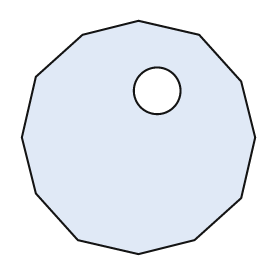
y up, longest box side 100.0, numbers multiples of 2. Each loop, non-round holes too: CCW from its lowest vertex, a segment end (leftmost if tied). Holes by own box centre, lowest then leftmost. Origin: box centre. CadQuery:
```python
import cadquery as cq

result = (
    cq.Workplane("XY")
    .moveTo(0.0, -50.0)
    .lineTo(24.0, -44.0)
    .lineTo(44.0, -26.0)
    .lineTo(50.0, 0.0)
    .lineTo(44.0, 24.0)
    .lineTo(26.0, 44.0)
    .lineTo(0.0, 50.0)
    .lineTo(-24.0, 44.0)
    .lineTo(-44.0, 26.0)
    .lineTo(-50.0, 0.0)
    .lineTo(-44.0, -24.0)
    .lineTo(-26.0, -44.0)
    .close()
    .moveTo(8.0, 20.0)
    .circle(10.0)
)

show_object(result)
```